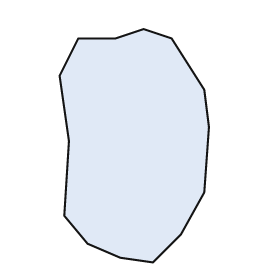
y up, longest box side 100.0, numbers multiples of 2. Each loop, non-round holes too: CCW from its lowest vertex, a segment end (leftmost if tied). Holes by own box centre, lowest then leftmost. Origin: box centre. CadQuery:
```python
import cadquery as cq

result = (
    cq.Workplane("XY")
    .moveTo(8.0, -50.0)
    .lineTo(20.0, -38.0)
    .lineTo(30.0, -20.0)
    .lineTo(32.0, 8.0)
    .lineTo(30.0, 24.0)
    .lineTo(16.0, 46.0)
    .lineTo(4.0, 50.0)
    .lineTo(-8.0, 46.0)
    .lineTo(-24.0, 46.0)
    .lineTo(-32.0, 30.0)
    .lineTo(-28.0, 2.0)
    .lineTo(-30.0, -30.0)
    .lineTo(-20.0, -42.0)
    .lineTo(-6.0, -48.0)
    .close()
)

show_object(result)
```